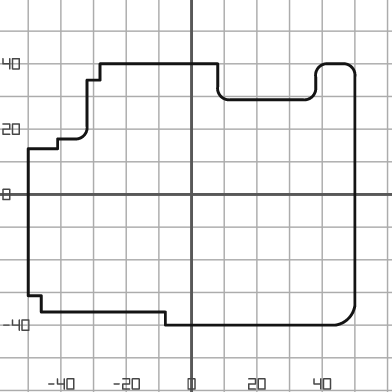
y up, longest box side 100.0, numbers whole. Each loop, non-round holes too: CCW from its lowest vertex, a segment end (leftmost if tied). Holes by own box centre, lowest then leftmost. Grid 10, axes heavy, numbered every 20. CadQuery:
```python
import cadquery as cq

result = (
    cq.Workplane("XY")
    .moveTo(-8.0, -40.0)
    .lineTo(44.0, -40.0)
    .threePointArc((48.0, -38.0), (50.0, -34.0))
    .lineTo(50.0, 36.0)
    .threePointArc((49.0, 39.0), (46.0, 40.0))
    .lineTo(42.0, 40.0)
    .threePointArc((39.0, 39.0), (38.0, 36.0))
    .lineTo(38.0, 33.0)
    .threePointArc((37.0, 30.0), (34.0, 29.0))
    .lineTo(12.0, 29.0)
    .threePointArc((9.0, 30.0), (8.0, 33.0))
    .lineTo(8.0, 40.0)
    .lineTo(-28.0, 40.0)
    .lineTo(-28.0, 35.0)
    .lineTo(-32.0, 35.0)
    .lineTo(-32.0, 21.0)
    .threePointArc((-33.0, 18.0), (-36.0, 17.0))
    .lineTo(-41.0, 17.0)
    .lineTo(-41.0, 14.0)
    .lineTo(-50.0, 14.0)
    .lineTo(-50.0, -31.0)
    .lineTo(-46.0, -31.0)
    .lineTo(-46.0, -36.0)
    .lineTo(-8.0, -36.0)
    .close()
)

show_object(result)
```